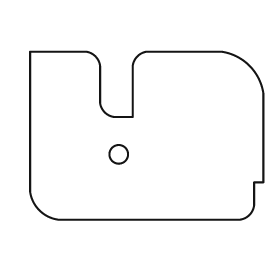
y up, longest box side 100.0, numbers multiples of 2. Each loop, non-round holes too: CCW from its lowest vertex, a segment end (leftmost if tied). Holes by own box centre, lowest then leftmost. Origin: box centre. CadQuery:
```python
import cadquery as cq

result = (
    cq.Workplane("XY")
    .moveTo(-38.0, -36.0)
    .lineTo(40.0, -36.0)
    .threePointArc((44.0, -34.0), (46.0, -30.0))
    .lineTo(46.0, -20.0)
    .lineTo(50.0, -20.0)
    .lineTo(50.0, 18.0)
    .threePointArc((44.0, 30.0), (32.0, 36.0))
    .lineTo(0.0, 36.0)
    .threePointArc((-4.0, 34.0), (-6.0, 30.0))
    .lineTo(-6.0, 8.0)
    .lineTo(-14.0, 8.0)
    .threePointArc((-18.0, 10.0), (-20.0, 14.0))
    .lineTo(-20.0, 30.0)
    .threePointArc((-22.0, 34.0), (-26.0, 36.0))
    .lineTo(-50.0, 36.0)
    .lineTo(-50.0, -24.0)
    .threePointArc((-46.0, -32.0), (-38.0, -36.0))
    .close()
    .moveTo(-12.0, -8.0)
    .circle(4.0)
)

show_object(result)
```